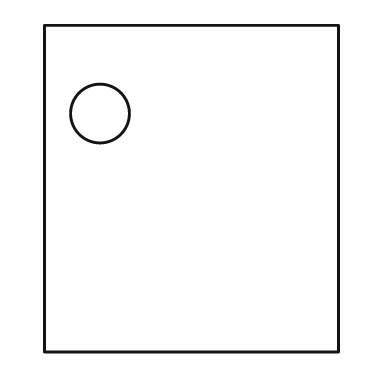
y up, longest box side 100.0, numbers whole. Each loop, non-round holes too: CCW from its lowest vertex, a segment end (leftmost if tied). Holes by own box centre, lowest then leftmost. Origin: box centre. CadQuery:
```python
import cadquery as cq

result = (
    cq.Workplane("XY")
    .moveTo(-45.0, -50.0)
    .lineTo(45.0, -50.0)
    .lineTo(45.0, 50.0)
    .lineTo(-45.0, 50.0)
    .close()
    .moveTo(-28.0, 23.0)
    .circle(9.0)
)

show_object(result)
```